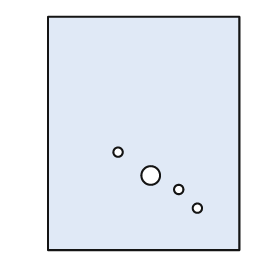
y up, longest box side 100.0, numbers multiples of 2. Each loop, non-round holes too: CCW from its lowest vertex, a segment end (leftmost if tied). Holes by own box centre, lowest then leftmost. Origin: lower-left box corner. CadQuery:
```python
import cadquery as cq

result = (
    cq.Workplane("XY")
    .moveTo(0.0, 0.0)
    .lineTo(82.0, 0.0)
    .lineTo(82.0, 100.0)
    .lineTo(0.0, 100.0)
    .close()
    .moveTo(64.0, 18.0)
    .circle(2.0)
    .moveTo(56.0, 26.0)
    .circle(2.0)
    .moveTo(44.0, 32.0)
    .circle(4.0)
    .moveTo(30.0, 42.0)
    .circle(2.0)
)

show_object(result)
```